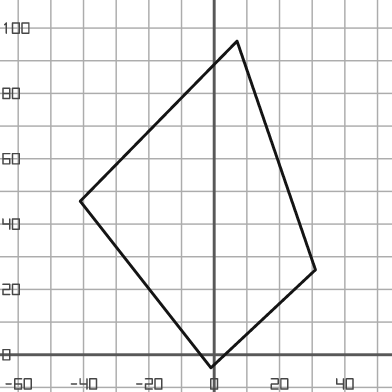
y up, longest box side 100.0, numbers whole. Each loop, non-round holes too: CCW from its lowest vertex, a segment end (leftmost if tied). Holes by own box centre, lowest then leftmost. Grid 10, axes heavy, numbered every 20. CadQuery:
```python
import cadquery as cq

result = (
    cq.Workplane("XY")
    .moveTo(-1.0, -4.0)
    .lineTo(31.0, 26.0)
    .lineTo(7.0, 96.0)
    .lineTo(-41.0, 47.0)
    .close()
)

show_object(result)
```